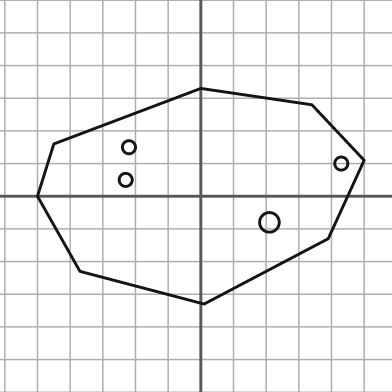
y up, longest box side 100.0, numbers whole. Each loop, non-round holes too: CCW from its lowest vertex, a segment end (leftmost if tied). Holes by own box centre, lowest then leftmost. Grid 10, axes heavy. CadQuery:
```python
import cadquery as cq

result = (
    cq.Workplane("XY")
    .moveTo(1.0, -33.0)
    .lineTo(39.0, -13.0)
    .lineTo(50.0, 11.0)
    .lineTo(34.0, 28.0)
    .lineTo(0.0, 33.0)
    .lineTo(-45.0, 16.0)
    .lineTo(-50.0, 0.0)
    .lineTo(-37.0, -23.0)
    .close()
    .moveTo(21.0, -8.0)
    .circle(3.0)
    .moveTo(-23.0, 5.0)
    .circle(2.0)
    .moveTo(43.0, 10.0)
    .circle(2.0)
    .moveTo(-22.0, 15.0)
    .circle(2.0)
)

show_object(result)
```